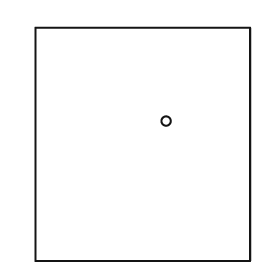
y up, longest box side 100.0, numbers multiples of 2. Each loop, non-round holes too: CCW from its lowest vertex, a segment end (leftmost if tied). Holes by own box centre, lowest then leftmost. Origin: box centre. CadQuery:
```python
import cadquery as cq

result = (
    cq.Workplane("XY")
    .moveTo(-46.0, -50.0)
    .lineTo(46.0, -50.0)
    .lineTo(46.0, 50.0)
    .lineTo(-46.0, 50.0)
    .close()
    .moveTo(10.0, 10.0)
    .circle(2.0)
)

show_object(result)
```